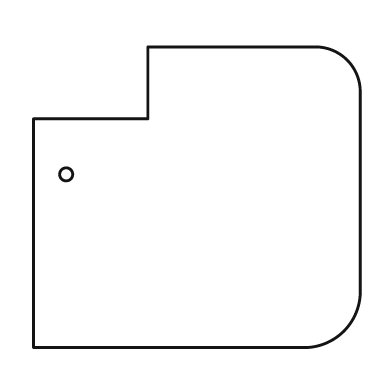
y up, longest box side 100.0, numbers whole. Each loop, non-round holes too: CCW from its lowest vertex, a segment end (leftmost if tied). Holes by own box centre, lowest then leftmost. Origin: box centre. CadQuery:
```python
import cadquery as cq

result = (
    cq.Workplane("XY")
    .moveTo(-50.0, -46.0)
    .lineTo(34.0, -46.0)
    .threePointArc((45.0, -41.0), (50.0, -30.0))
    .lineTo(50.0, 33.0)
    .threePointArc((46.0, 42.0), (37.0, 46.0))
    .lineTo(-15.0, 46.0)
    .lineTo(-15.0, 24.0)
    .lineTo(-50.0, 24.0)
    .close()
    .moveTo(-40.0, 7.0)
    .circle(2.0)
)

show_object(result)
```